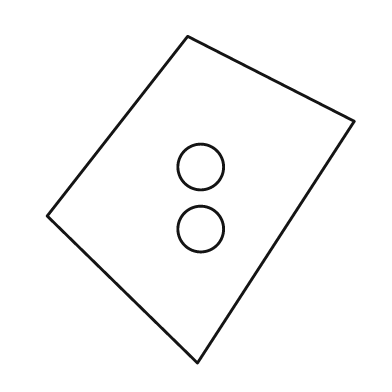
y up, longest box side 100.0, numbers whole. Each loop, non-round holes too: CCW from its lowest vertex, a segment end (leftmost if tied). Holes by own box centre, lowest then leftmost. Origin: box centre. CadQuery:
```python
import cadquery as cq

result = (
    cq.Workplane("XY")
    .moveTo(-1.0, -50.0)
    .lineTo(47.0, 24.0)
    .lineTo(-4.0, 50.0)
    .lineTo(-47.0, -5.0)
    .close()
    .moveTo(0.0, -9.0)
    .circle(7.0)
    .moveTo(0.0, 10.0)
    .circle(7.0)
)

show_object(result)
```